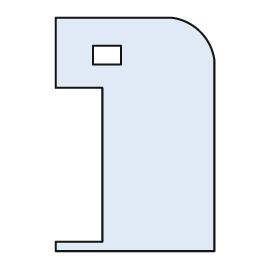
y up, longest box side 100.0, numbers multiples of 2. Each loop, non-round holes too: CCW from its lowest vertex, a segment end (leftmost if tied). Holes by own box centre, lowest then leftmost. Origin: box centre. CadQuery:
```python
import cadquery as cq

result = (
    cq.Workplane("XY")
    .moveTo(-34.0, -50.0)
    .lineTo(34.0, -50.0)
    .lineTo(34.0, 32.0)
    .threePointArc((28.0, 44.0), (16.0, 50.0))
    .lineTo(-34.0, 50.0)
    .lineTo(-34.0, 20.0)
    .lineTo(-14.0, 20.0)
    .lineTo(-14.0, -46.0)
    .lineTo(-34.0, -46.0)
    .close()
    .moveTo(-18.0, 30.0)
    .lineTo(-6.0, 30.0)
    .lineTo(-6.0, 38.0)
    .lineTo(-18.0, 38.0)
    .close()
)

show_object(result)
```